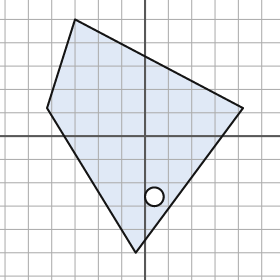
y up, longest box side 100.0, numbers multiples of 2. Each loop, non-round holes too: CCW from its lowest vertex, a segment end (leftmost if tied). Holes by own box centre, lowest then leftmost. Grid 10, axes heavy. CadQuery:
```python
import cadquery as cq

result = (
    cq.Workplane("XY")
    .moveTo(-4.0, -50.0)
    .lineTo(42.0, 12.0)
    .lineTo(-30.0, 50.0)
    .lineTo(-42.0, 12.0)
    .close()
    .moveTo(4.0, -26.0)
    .circle(4.0)
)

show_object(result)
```